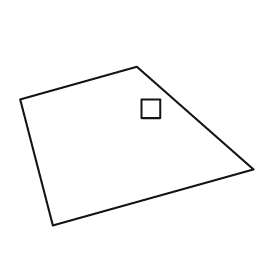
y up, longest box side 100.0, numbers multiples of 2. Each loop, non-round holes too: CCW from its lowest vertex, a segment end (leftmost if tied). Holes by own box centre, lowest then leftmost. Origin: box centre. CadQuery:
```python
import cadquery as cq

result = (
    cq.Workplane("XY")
    .moveTo(-36.0, -34.0)
    .lineTo(50.0, -10.0)
    .lineTo(0.0, 34.0)
    .lineTo(-50.0, 20.0)
    .close()
    .moveTo(2.0, 12.0)
    .lineTo(10.0, 12.0)
    .lineTo(10.0, 20.0)
    .lineTo(2.0, 20.0)
    .close()
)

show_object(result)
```